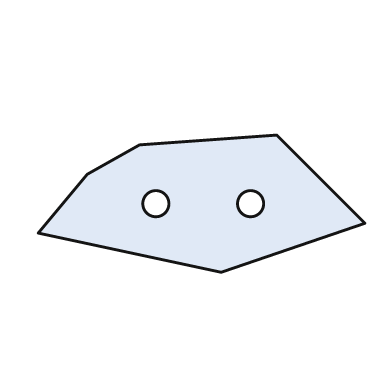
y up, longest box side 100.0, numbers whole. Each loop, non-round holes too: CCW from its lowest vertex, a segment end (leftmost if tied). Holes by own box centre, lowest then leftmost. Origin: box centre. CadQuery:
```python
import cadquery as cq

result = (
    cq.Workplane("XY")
    .moveTo(6.0, -21.0)
    .lineTo(50.0, -6.0)
    .lineTo(23.0, 21.0)
    .lineTo(-19.0, 18.0)
    .lineTo(-35.0, 9.0)
    .lineTo(-50.0, -9.0)
    .close()
    .moveTo(-14.0, 0.0)
    .circle(4.0)
    .moveTo(15.0, 0.0)
    .circle(4.0)
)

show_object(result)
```